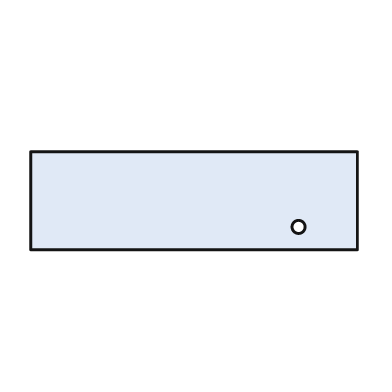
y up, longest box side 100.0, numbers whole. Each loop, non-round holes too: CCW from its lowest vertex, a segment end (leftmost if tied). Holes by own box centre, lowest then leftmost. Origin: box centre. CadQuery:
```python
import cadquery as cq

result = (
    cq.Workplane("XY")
    .moveTo(-50.0, -15.0)
    .lineTo(50.0, -15.0)
    .lineTo(50.0, 15.0)
    .lineTo(-50.0, 15.0)
    .close()
    .moveTo(32.0, -8.0)
    .circle(2.0)
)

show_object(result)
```